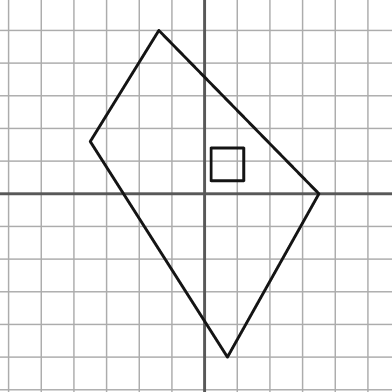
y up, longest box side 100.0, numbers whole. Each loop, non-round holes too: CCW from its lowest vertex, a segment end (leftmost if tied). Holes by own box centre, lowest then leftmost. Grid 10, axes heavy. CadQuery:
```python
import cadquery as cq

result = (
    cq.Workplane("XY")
    .moveTo(7.0, -50.0)
    .lineTo(35.0, 0.0)
    .lineTo(-14.0, 50.0)
    .lineTo(-35.0, 16.0)
    .close()
    .moveTo(2.0, 4.0)
    .lineTo(12.0, 4.0)
    .lineTo(12.0, 14.0)
    .lineTo(2.0, 14.0)
    .close()
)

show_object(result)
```